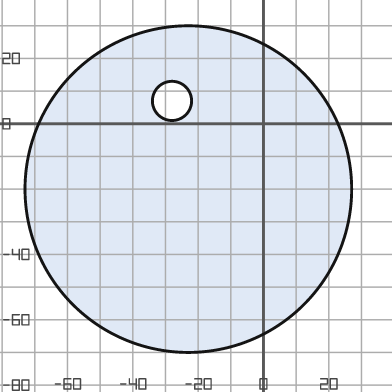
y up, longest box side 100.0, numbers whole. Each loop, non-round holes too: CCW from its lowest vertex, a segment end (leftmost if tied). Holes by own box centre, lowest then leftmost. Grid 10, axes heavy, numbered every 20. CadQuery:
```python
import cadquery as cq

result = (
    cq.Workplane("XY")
    .moveTo(-23.0, -20.0)
    .circle(50.0)
    .moveTo(-28.0, 7.0)
    .circle(6.0)
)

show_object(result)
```